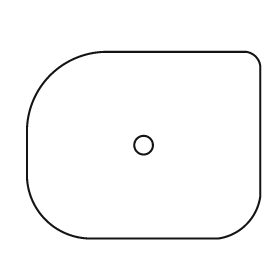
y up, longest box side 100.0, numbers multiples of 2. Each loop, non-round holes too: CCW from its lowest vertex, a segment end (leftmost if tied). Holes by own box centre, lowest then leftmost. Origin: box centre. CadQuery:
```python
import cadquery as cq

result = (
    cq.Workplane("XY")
    .moveTo(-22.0, -40.0)
    .lineTo(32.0, -40.0)
    .threePointArc((44.0, -34.0), (50.0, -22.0))
    .lineTo(50.0, 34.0)
    .threePointArc((48.0, 38.0), (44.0, 40.0))
    .lineTo(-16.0, 40.0)
    .threePointArc((-40.0, 30.0), (-50.0, 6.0))
    .lineTo(-50.0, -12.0)
    .threePointArc((-42.0, -32.0), (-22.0, -40.0))
    .close()
    .moveTo(0.0, 0.0)
    .circle(4.0)
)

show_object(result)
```